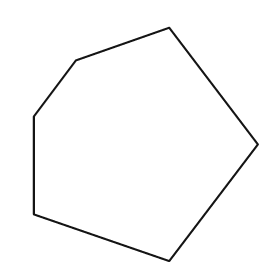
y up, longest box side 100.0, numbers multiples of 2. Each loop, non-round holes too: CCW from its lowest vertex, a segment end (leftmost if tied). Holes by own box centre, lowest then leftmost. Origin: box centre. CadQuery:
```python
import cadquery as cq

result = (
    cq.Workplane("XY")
    .moveTo(10.0, -50.0)
    .lineTo(48.0, 0.0)
    .lineTo(10.0, 50.0)
    .lineTo(-30.0, 36.0)
    .lineTo(-48.0, 12.0)
    .lineTo(-48.0, -30.0)
    .close()
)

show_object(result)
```